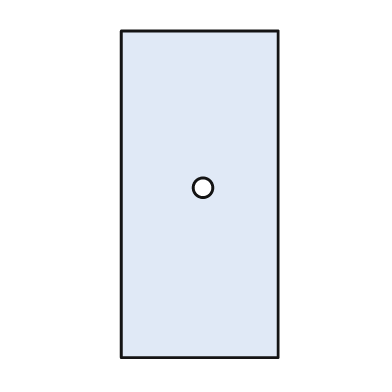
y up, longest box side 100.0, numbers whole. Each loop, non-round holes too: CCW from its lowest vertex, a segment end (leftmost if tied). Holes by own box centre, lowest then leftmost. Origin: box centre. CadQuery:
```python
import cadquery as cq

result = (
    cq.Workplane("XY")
    .moveTo(-24.0, -50.0)
    .lineTo(24.0, -50.0)
    .lineTo(24.0, 50.0)
    .lineTo(-24.0, 50.0)
    .close()
    .moveTo(1.0, 2.0)
    .circle(3.0)
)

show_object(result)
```